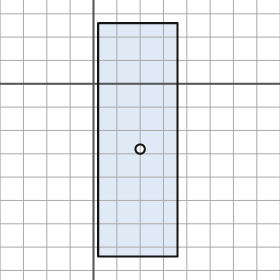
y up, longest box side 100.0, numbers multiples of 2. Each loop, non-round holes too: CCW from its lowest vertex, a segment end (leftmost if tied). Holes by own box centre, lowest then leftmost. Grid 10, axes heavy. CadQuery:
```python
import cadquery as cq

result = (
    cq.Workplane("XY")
    .moveTo(2.0, -74.0)
    .lineTo(36.0, -74.0)
    .lineTo(36.0, 26.0)
    .lineTo(2.0, 26.0)
    .close()
    .moveTo(20.0, -28.0)
    .circle(2.0)
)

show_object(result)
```